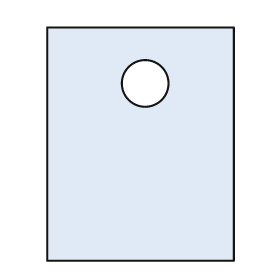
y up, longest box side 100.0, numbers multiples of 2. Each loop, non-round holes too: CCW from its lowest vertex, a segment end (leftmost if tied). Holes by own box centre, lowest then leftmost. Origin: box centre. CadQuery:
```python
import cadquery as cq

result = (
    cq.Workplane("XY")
    .moveTo(-40.0, -50.0)
    .lineTo(40.0, -50.0)
    .lineTo(40.0, 50.0)
    .lineTo(-40.0, 50.0)
    .close()
    .moveTo(2.0, 26.0)
    .circle(10.0)
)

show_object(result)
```